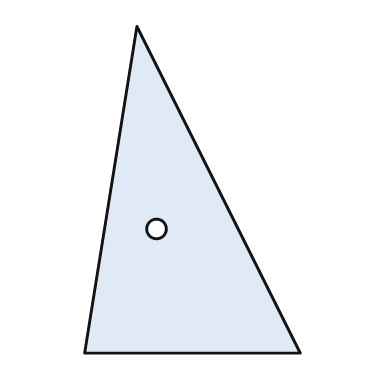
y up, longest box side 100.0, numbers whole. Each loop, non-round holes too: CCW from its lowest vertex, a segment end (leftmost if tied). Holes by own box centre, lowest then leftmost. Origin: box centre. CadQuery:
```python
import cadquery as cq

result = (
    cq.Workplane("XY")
    .moveTo(-33.0, -50.0)
    .lineTo(33.0, -50.0)
    .lineTo(-17.0, 50.0)
    .close()
    .moveTo(-11.0, -12.0)
    .circle(3.0)
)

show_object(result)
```